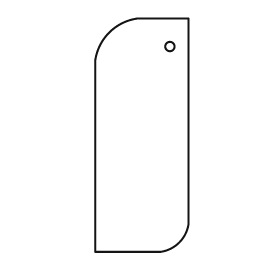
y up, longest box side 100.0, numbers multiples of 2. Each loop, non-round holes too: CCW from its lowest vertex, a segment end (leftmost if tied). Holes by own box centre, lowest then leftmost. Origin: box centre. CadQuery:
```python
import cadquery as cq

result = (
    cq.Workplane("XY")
    .moveTo(-20.0, -50.0)
    .lineTo(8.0, -50.0)
    .threePointArc((16.0, -46.0), (20.0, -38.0))
    .lineTo(20.0, 50.0)
    .lineTo(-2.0, 50.0)
    .threePointArc((-14.0, 44.0), (-20.0, 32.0))
    .close()
    .moveTo(12.0, 38.0)
    .circle(2.0)
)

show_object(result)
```